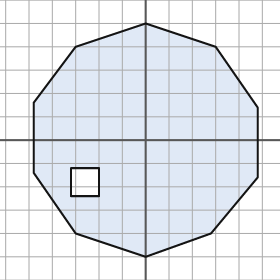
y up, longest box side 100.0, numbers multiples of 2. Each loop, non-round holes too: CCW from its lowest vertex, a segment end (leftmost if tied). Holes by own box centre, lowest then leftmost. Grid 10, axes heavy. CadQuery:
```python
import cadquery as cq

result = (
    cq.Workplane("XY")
    .moveTo(0.0, -50.0)
    .lineTo(28.0, -40.0)
    .lineTo(48.0, -16.0)
    .lineTo(48.0, 14.0)
    .lineTo(30.0, 40.0)
    .lineTo(0.0, 50.0)
    .lineTo(-30.0, 40.0)
    .lineTo(-48.0, 16.0)
    .lineTo(-48.0, -14.0)
    .lineTo(-30.0, -40.0)
    .close()
    .moveTo(-32.0, -24.0)
    .lineTo(-20.0, -24.0)
    .lineTo(-20.0, -12.0)
    .lineTo(-32.0, -12.0)
    .close()
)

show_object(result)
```